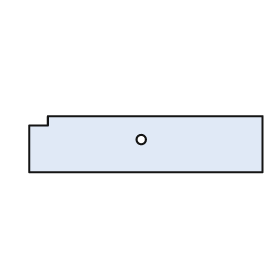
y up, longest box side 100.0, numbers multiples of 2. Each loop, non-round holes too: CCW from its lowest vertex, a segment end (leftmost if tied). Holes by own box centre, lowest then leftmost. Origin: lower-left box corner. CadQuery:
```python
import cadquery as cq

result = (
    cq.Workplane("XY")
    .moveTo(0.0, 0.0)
    .lineTo(100.0, 0.0)
    .lineTo(100.0, 24.0)
    .lineTo(8.0, 24.0)
    .lineTo(8.0, 20.0)
    .lineTo(0.0, 20.0)
    .close()
    .moveTo(48.0, 14.0)
    .circle(2.0)
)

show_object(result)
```